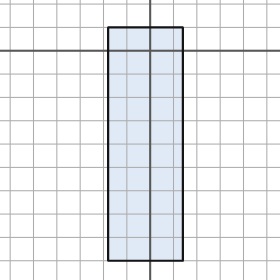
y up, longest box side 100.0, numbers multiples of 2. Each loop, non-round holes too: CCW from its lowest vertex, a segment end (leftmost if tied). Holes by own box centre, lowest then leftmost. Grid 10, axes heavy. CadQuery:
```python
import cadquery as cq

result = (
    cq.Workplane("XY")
    .moveTo(-18.0, -90.0)
    .lineTo(14.0, -90.0)
    .lineTo(14.0, 10.0)
    .lineTo(-18.0, 10.0)
    .close()
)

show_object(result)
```